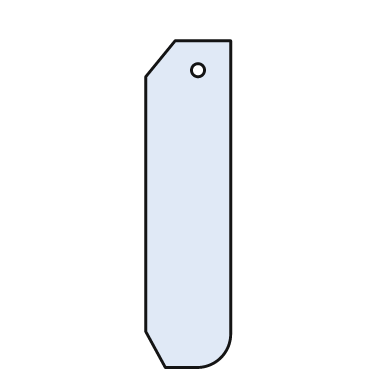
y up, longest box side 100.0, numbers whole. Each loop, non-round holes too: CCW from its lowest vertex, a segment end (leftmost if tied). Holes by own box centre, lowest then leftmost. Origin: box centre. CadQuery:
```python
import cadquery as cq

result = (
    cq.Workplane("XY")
    .moveTo(-7.0, -50.0)
    .lineTo(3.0, -50.0)
    .threePointArc((10.0, -47.0), (13.0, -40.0))
    .lineTo(13.0, 50.0)
    .lineTo(-4.0, 50.0)
    .lineTo(-13.0, 39.0)
    .lineTo(-13.0, -39.0)
    .close()
    .moveTo(3.0, 41.0)
    .circle(2.0)
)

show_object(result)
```